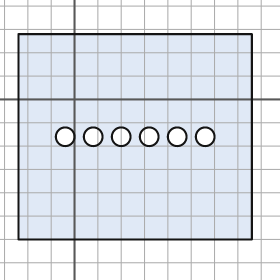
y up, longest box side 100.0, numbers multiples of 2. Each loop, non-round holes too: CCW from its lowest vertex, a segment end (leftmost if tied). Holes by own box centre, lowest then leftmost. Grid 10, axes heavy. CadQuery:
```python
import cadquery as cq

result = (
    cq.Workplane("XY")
    .moveTo(-24.0, -60.0)
    .lineTo(76.0, -60.0)
    .lineTo(76.0, 28.0)
    .lineTo(-24.0, 28.0)
    .close()
    .moveTo(-4.0, -16.0)
    .circle(4.0)
    .moveTo(8.0, -16.0)
    .circle(4.0)
    .moveTo(20.0, -16.0)
    .circle(4.0)
    .moveTo(32.0, -16.0)
    .circle(4.0)
    .moveTo(44.0, -16.0)
    .circle(4.0)
    .moveTo(56.0, -16.0)
    .circle(4.0)
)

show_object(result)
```